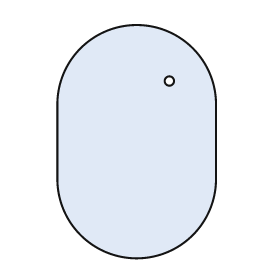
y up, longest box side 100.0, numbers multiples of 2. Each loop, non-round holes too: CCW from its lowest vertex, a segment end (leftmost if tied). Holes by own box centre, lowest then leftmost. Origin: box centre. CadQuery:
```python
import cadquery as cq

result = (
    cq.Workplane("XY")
    .moveTo(-34.0, -16.0)
    .threePointArc((0.0, -50.0), (34.0, -16.0))
    .lineTo(34.0, 16.0)
    .threePointArc((0.0, 50.0), (-34.0, 16.0))
    .close()
    .moveTo(14.0, 26.0)
    .circle(2.0)
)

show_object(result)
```